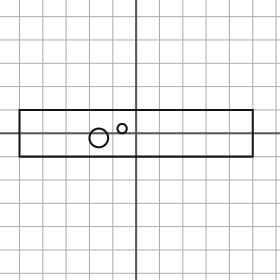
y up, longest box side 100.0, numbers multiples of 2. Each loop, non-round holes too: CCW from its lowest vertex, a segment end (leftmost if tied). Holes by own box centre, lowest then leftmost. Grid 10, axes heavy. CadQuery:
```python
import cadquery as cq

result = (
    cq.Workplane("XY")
    .moveTo(-50.0, -10.0)
    .lineTo(50.0, -10.0)
    .lineTo(50.0, 10.0)
    .lineTo(-50.0, 10.0)
    .close()
    .moveTo(-16.0, -2.0)
    .circle(4.0)
    .moveTo(-6.0, 2.0)
    .circle(2.0)
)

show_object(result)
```